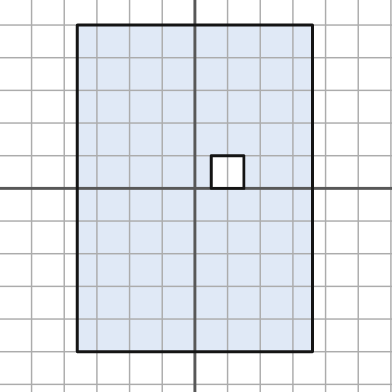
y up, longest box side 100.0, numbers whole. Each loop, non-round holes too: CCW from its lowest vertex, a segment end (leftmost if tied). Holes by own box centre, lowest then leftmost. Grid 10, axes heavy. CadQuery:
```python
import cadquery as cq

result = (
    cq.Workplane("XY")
    .moveTo(-36.0, -50.0)
    .lineTo(36.0, -50.0)
    .lineTo(36.0, 50.0)
    .lineTo(-36.0, 50.0)
    .close()
    .moveTo(5.0, 0.0)
    .lineTo(15.0, 0.0)
    .lineTo(15.0, 10.0)
    .lineTo(5.0, 10.0)
    .close()
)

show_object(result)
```